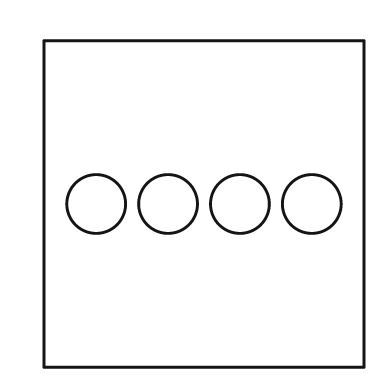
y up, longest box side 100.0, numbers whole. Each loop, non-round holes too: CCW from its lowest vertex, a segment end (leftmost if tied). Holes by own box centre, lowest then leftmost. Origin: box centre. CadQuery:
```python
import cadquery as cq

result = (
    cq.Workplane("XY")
    .moveTo(-49.0, -50.0)
    .lineTo(49.0, -50.0)
    .lineTo(49.0, 50.0)
    .lineTo(-49.0, 50.0)
    .close()
    .moveTo(-33.0, 0.0)
    .circle(9.0)
    .moveTo(-11.0, 0.0)
    .circle(9.0)
    .moveTo(11.0, 0.0)
    .circle(9.0)
    .moveTo(33.0, 0.0)
    .circle(9.0)
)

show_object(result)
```